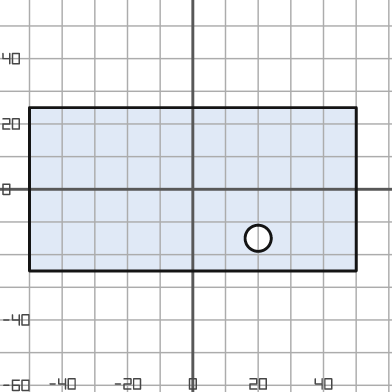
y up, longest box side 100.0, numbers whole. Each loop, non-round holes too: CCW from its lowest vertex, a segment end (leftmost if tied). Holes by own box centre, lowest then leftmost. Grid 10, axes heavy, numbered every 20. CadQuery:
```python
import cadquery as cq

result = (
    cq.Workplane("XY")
    .moveTo(-50.0, -25.0)
    .lineTo(50.0, -25.0)
    .lineTo(50.0, 25.0)
    .lineTo(-50.0, 25.0)
    .close()
    .moveTo(20.0, -15.0)
    .circle(4.0)
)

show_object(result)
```